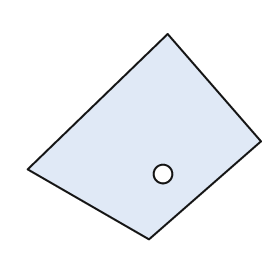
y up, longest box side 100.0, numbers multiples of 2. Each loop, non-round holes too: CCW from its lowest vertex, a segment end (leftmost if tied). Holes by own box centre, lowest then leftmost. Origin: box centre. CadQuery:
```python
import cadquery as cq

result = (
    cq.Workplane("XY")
    .moveTo(2.0, -44.0)
    .lineTo(50.0, -2.0)
    .lineTo(10.0, 44.0)
    .lineTo(-50.0, -14.0)
    .close()
    .moveTo(8.0, -16.0)
    .circle(4.0)
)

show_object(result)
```